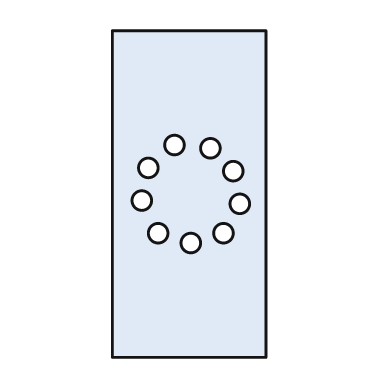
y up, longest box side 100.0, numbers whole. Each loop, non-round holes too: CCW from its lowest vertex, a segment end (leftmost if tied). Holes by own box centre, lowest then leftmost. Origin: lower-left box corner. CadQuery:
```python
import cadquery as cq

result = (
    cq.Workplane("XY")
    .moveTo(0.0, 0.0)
    .lineTo(47.0, 0.0)
    .lineTo(47.0, 100.0)
    .lineTo(0.0, 100.0)
    .close()
    .moveTo(24.0, 35.0)
    .circle(3.0)
    .moveTo(14.0, 38.0)
    .circle(3.0)
    .moveTo(34.0, 38.0)
    .circle(3.0)
    .moveTo(39.0, 47.0)
    .circle(3.0)
    .moveTo(9.0, 48.0)
    .circle(3.0)
    .moveTo(37.0, 57.0)
    .circle(3.0)
    .moveTo(11.0, 58.0)
    .circle(3.0)
    .moveTo(30.0, 64.0)
    .circle(3.0)
    .moveTo(19.0, 65.0)
    .circle(3.0)
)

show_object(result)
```